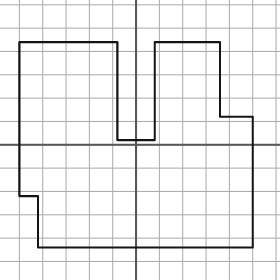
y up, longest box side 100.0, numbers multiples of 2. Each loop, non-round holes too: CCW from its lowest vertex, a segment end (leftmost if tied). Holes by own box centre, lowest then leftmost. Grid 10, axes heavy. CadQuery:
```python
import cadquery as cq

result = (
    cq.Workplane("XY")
    .moveTo(-42.0, -44.0)
    .lineTo(50.0, -44.0)
    .lineTo(50.0, 12.0)
    .lineTo(36.0, 12.0)
    .lineTo(36.0, 44.0)
    .lineTo(8.0, 44.0)
    .lineTo(8.0, 2.0)
    .lineTo(-8.0, 2.0)
    .lineTo(-8.0, 44.0)
    .lineTo(-50.0, 44.0)
    .lineTo(-50.0, -22.0)
    .lineTo(-42.0, -22.0)
    .close()
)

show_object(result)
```